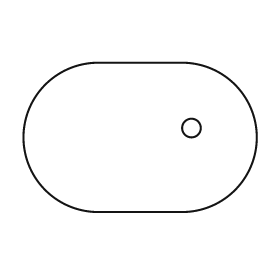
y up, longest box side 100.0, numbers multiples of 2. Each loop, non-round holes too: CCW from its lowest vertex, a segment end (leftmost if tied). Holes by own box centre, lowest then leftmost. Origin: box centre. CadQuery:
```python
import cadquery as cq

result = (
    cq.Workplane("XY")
    .moveTo(-18.0, -32.0)
    .lineTo(18.0, -32.0)
    .threePointArc((50.0, 0.0), (18.0, 32.0))
    .lineTo(-18.0, 32.0)
    .threePointArc((-50.0, 0.0), (-18.0, -32.0))
    .close()
    .moveTo(22.0, 4.0)
    .circle(4.0)
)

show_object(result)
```